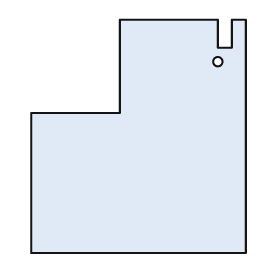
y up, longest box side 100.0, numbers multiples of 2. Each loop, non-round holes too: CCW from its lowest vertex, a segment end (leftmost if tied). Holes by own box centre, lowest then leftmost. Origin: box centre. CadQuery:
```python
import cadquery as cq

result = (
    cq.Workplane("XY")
    .moveTo(-46.0, -50.0)
    .lineTo(46.0, -50.0)
    .lineTo(46.0, 50.0)
    .lineTo(40.0, 50.0)
    .lineTo(40.0, 38.0)
    .lineTo(34.0, 38.0)
    .lineTo(34.0, 50.0)
    .lineTo(-8.0, 50.0)
    .lineTo(-8.0, 10.0)
    .lineTo(-46.0, 10.0)
    .close()
    .moveTo(34.0, 32.0)
    .circle(2.0)
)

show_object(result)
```